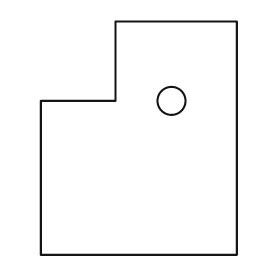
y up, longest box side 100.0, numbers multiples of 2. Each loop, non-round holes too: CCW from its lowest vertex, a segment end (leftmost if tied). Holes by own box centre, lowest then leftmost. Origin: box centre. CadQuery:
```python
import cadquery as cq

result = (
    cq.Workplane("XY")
    .moveTo(-42.0, -50.0)
    .lineTo(42.0, -50.0)
    .lineTo(42.0, 50.0)
    .lineTo(-10.0, 50.0)
    .lineTo(-10.0, 16.0)
    .lineTo(-42.0, 16.0)
    .close()
    .moveTo(14.0, 16.0)
    .circle(6.0)
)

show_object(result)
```